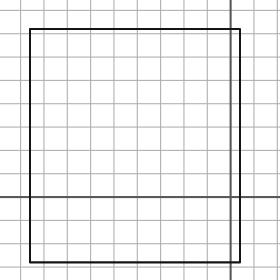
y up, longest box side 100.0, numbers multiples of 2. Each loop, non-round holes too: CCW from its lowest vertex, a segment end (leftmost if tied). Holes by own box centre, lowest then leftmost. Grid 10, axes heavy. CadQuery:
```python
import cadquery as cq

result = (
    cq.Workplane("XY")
    .moveTo(-86.0, -28.0)
    .lineTo(4.0, -28.0)
    .lineTo(4.0, 72.0)
    .lineTo(-86.0, 72.0)
    .close()
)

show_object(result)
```